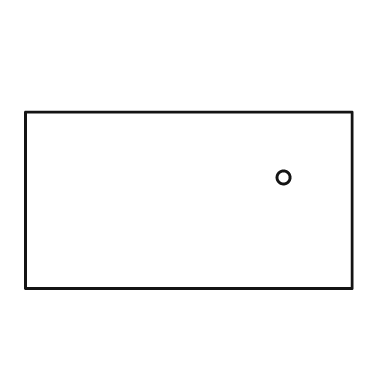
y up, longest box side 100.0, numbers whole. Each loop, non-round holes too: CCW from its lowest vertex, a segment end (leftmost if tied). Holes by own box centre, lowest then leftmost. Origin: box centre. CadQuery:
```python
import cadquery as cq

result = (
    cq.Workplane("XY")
    .moveTo(-50.0, -27.0)
    .lineTo(50.0, -27.0)
    .lineTo(50.0, 27.0)
    .lineTo(-50.0, 27.0)
    .close()
    .moveTo(29.0, 7.0)
    .circle(2.0)
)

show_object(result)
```